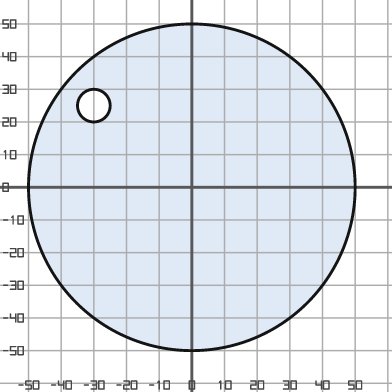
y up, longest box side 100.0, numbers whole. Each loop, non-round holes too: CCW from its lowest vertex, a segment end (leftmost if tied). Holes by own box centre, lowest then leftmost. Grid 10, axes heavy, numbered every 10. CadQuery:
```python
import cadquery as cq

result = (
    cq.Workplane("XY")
    .moveTo(0.0, 0.0)
    .circle(50.0)
    .moveTo(-30.0, 25.0)
    .circle(5.0)
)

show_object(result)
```